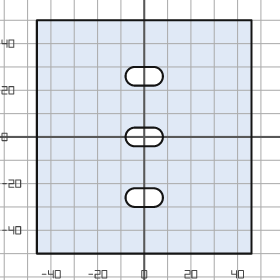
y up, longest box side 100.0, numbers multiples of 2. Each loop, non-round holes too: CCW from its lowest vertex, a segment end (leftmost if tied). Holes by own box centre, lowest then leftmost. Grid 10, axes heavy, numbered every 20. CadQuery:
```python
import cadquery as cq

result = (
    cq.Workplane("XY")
    .moveTo(-46.0, -50.0)
    .lineTo(46.0, -50.0)
    .lineTo(46.0, 50.0)
    .lineTo(-46.0, 50.0)
    .close()
    .moveTo(-4.0, -30.0)
    .lineTo(4.0, -30.0)
    .threePointArc((8.0, -26.0), (4.0, -22.0))
    .lineTo(-4.0, -22.0)
    .threePointArc((-8.0, -26.0), (-4.0, -30.0))
    .close()
    .moveTo(-4.0, -4.0)
    .lineTo(4.0, -4.0)
    .threePointArc((8.0, 0.0), (4.0, 4.0))
    .lineTo(-4.0, 4.0)
    .threePointArc((-8.0, 0.0), (-4.0, -4.0))
    .close()
    .moveTo(-4.0, 22.0)
    .lineTo(4.0, 22.0)
    .threePointArc((8.0, 26.0), (4.0, 30.0))
    .lineTo(-4.0, 30.0)
    .threePointArc((-8.0, 26.0), (-4.0, 22.0))
    .close()
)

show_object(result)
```